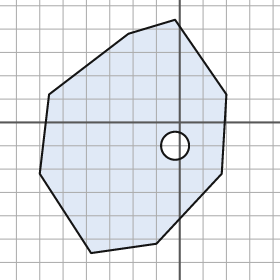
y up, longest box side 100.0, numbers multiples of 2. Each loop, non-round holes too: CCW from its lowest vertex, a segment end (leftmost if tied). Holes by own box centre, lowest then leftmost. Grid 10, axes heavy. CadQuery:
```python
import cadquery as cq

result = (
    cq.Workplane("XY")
    .moveTo(-38.0, -56.0)
    .lineTo(-10.0, -52.0)
    .lineTo(18.0, -22.0)
    .lineTo(20.0, 12.0)
    .lineTo(-2.0, 44.0)
    .lineTo(-22.0, 38.0)
    .lineTo(-56.0, 12.0)
    .lineTo(-60.0, -22.0)
    .close()
    .moveTo(-2.0, -10.0)
    .circle(6.0)
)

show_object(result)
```